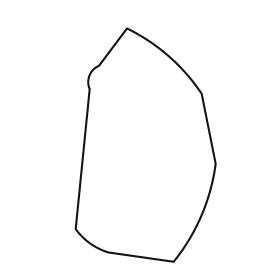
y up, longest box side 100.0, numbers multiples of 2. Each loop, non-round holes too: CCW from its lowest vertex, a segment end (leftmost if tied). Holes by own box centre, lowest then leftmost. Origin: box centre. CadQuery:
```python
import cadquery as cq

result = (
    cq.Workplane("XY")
    .moveTo(12.0, -50.0)
    .threePointArc((24.0, -30.0), (30.0, -8.0))
    .lineTo(24.0, 22.0)
    .threePointArc((10.0, 38.0), (-8.0, 50.0))
    .lineTo(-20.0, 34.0)
    .threePointArc((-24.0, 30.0), (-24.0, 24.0))
    .lineTo(-30.0, -36.0)
    .threePointArc((-24.0, -42.0), (-16.0, -46.0))
    .close()
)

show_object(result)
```